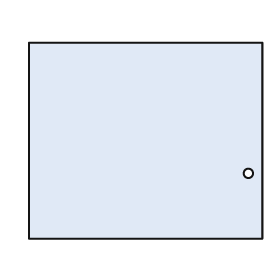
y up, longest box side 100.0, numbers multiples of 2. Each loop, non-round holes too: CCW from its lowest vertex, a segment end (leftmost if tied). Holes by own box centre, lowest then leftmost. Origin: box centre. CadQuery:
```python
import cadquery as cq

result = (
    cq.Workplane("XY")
    .moveTo(-50.0, -42.0)
    .lineTo(50.0, -42.0)
    .lineTo(50.0, 42.0)
    .lineTo(-50.0, 42.0)
    .close()
    .moveTo(44.0, -14.0)
    .circle(2.0)
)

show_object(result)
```